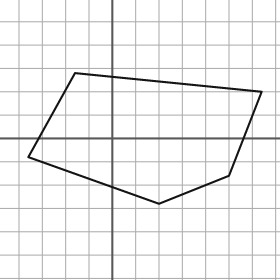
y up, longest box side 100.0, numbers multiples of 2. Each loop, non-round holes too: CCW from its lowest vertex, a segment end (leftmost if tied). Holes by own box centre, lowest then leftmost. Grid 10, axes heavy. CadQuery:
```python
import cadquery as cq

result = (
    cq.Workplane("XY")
    .moveTo(20.0, -28.0)
    .lineTo(50.0, -16.0)
    .lineTo(64.0, 20.0)
    .lineTo(-16.0, 28.0)
    .lineTo(-36.0, -8.0)
    .close()
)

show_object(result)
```